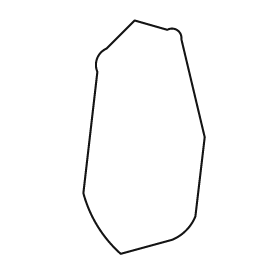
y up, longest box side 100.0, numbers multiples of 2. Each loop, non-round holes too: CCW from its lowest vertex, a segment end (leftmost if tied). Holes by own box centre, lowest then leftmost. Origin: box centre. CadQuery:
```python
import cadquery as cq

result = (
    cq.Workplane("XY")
    .moveTo(-10.0, -50.0)
    .lineTo(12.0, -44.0)
    .threePointArc((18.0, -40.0), (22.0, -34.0))
    .lineTo(26.0, 0.0)
    .lineTo(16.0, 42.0)
    .threePointArc((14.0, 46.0), (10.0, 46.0))
    .lineTo(-4.0, 50.0)
    .lineTo(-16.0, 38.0)
    .threePointArc((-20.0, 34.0), (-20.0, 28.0))
    .lineTo(-26.0, -24.0)
    .threePointArc((-20.0, -38.0), (-10.0, -50.0))
    .close()
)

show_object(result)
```